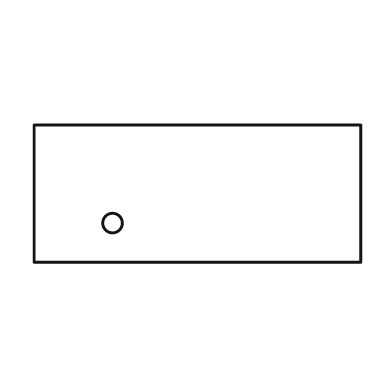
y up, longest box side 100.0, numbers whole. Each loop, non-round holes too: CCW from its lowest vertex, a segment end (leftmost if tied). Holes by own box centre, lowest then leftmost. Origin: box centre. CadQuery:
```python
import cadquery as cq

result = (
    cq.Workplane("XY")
    .moveTo(-50.0, -21.0)
    .lineTo(50.0, -21.0)
    .lineTo(50.0, 21.0)
    .lineTo(-50.0, 21.0)
    .close()
    .moveTo(-26.0, -9.0)
    .circle(3.0)
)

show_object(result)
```